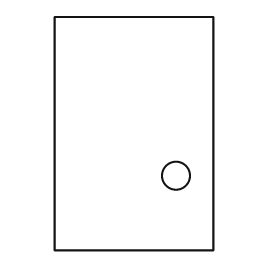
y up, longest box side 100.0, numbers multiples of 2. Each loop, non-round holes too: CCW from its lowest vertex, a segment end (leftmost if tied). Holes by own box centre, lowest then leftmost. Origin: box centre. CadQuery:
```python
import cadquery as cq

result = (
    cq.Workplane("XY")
    .moveTo(-34.0, -50.0)
    .lineTo(34.0, -50.0)
    .lineTo(34.0, 50.0)
    .lineTo(-34.0, 50.0)
    .close()
    .moveTo(18.0, -18.0)
    .circle(6.0)
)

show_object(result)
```